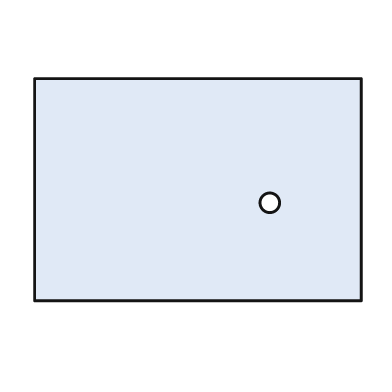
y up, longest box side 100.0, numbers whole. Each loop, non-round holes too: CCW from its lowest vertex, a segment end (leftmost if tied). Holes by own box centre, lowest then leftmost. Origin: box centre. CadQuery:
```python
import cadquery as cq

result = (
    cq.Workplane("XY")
    .moveTo(-50.0, -34.0)
    .lineTo(50.0, -34.0)
    .lineTo(50.0, 34.0)
    .lineTo(-50.0, 34.0)
    .close()
    .moveTo(22.0, -4.0)
    .circle(3.0)
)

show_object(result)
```